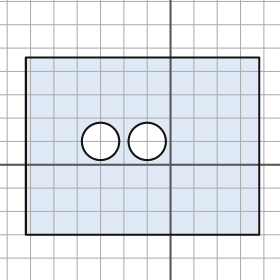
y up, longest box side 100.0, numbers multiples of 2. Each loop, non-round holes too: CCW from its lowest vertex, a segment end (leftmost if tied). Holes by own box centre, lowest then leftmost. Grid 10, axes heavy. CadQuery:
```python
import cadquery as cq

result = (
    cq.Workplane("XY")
    .moveTo(-62.0, -30.0)
    .lineTo(38.0, -30.0)
    .lineTo(38.0, 46.0)
    .lineTo(-62.0, 46.0)
    .close()
    .moveTo(-30.0, 10.0)
    .circle(8.0)
    .moveTo(-10.0, 10.0)
    .circle(8.0)
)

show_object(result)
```